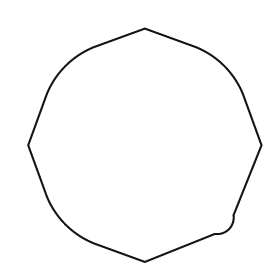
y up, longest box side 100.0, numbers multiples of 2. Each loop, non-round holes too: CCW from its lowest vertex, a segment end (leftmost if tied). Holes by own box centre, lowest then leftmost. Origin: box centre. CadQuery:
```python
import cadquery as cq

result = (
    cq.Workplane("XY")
    .moveTo(0.0, -50.0)
    .lineTo(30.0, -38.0)
    .threePointArc((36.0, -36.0), (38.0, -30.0))
    .lineTo(50.0, 0.0)
    .lineTo(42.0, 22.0)
    .threePointArc((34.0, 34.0), (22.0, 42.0))
    .lineTo(0.0, 50.0)
    .lineTo(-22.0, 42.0)
    .threePointArc((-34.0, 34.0), (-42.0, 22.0))
    .lineTo(-50.0, 0.0)
    .lineTo(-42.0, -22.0)
    .threePointArc((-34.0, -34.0), (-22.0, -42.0))
    .close()
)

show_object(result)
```